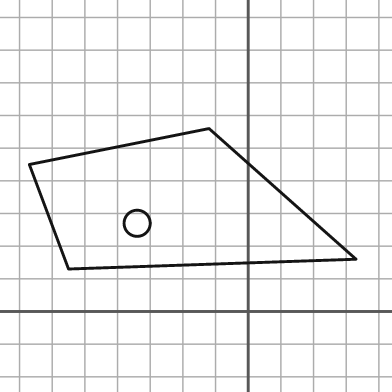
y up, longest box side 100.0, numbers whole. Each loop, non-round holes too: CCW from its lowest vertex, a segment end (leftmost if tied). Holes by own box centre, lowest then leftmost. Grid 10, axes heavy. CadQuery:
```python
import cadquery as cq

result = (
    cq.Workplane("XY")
    .moveTo(-55.0, 13.0)
    .lineTo(33.0, 16.0)
    .lineTo(-12.0, 56.0)
    .lineTo(-67.0, 45.0)
    .close()
    .moveTo(-34.0, 27.0)
    .circle(4.0)
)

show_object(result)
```